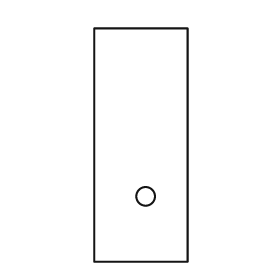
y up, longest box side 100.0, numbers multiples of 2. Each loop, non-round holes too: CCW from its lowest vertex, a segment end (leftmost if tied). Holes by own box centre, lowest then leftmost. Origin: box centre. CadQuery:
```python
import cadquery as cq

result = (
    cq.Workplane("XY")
    .moveTo(-20.0, -50.0)
    .lineTo(20.0, -50.0)
    .lineTo(20.0, 50.0)
    .lineTo(-20.0, 50.0)
    .close()
    .moveTo(2.0, -22.0)
    .circle(4.0)
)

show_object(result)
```